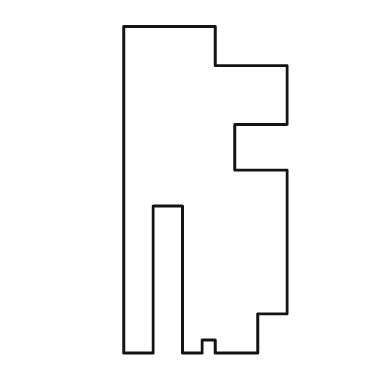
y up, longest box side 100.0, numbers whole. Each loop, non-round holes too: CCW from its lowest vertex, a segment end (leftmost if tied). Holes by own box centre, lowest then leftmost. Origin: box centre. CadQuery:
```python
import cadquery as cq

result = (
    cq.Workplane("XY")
    .moveTo(-25.0, -50.0)
    .lineTo(-16.0, -50.0)
    .lineTo(-16.0, -5.0)
    .lineTo(-7.0, -5.0)
    .lineTo(-7.0, -50.0)
    .lineTo(-1.0, -50.0)
    .lineTo(-1.0, -46.0)
    .lineTo(3.0, -46.0)
    .lineTo(3.0, -50.0)
    .lineTo(16.0, -50.0)
    .lineTo(16.0, -38.0)
    .lineTo(25.0, -38.0)
    .lineTo(25.0, 6.0)
    .lineTo(9.0, 6.0)
    .lineTo(9.0, 20.0)
    .lineTo(25.0, 20.0)
    .lineTo(25.0, 38.0)
    .lineTo(3.0, 38.0)
    .lineTo(3.0, 50.0)
    .lineTo(-25.0, 50.0)
    .close()
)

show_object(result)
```